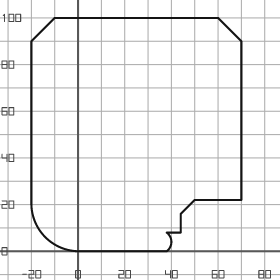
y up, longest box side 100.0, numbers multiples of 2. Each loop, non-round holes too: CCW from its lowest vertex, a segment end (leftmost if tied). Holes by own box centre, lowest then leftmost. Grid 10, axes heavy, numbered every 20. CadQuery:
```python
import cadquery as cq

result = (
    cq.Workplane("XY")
    .moveTo(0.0, 0.0)
    .lineTo(38.0, 0.0)
    .threePointArc((40.0, 4.0), (38.0, 8.0))
    .lineTo(44.0, 8.0)
    .lineTo(44.0, 16.0)
    .lineTo(50.0, 22.0)
    .lineTo(70.0, 22.0)
    .lineTo(70.0, 90.0)
    .lineTo(60.0, 100.0)
    .lineTo(-10.0, 100.0)
    .lineTo(-20.0, 90.0)
    .lineTo(-20.0, 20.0)
    .threePointArc((-14.0, 6.0), (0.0, 0.0))
    .close()
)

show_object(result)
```